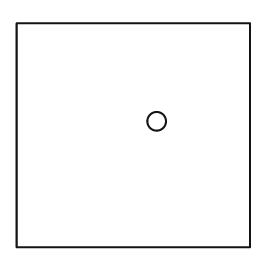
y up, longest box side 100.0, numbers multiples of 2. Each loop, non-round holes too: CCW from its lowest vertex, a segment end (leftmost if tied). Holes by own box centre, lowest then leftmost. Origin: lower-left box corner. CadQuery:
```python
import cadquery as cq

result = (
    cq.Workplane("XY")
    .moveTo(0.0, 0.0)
    .lineTo(100.0, 0.0)
    .lineTo(100.0, 96.0)
    .lineTo(0.0, 96.0)
    .close()
    .moveTo(60.0, 54.0)
    .circle(4.0)
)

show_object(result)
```